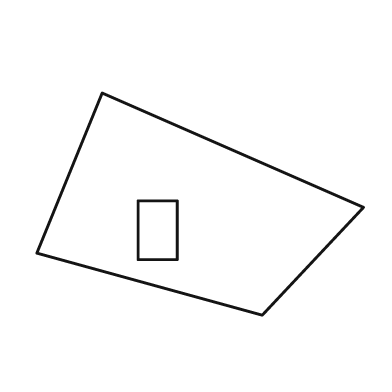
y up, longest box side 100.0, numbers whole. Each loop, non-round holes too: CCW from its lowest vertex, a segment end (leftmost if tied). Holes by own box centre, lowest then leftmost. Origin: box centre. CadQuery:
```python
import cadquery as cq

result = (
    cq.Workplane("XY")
    .moveTo(19.0, -34.0)
    .lineTo(50.0, -1.0)
    .lineTo(-30.0, 34.0)
    .lineTo(-50.0, -15.0)
    .close()
    .moveTo(-19.0, -17.0)
    .lineTo(-7.0, -17.0)
    .lineTo(-7.0, 1.0)
    .lineTo(-19.0, 1.0)
    .close()
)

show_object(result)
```